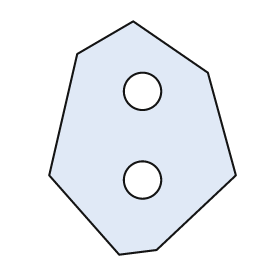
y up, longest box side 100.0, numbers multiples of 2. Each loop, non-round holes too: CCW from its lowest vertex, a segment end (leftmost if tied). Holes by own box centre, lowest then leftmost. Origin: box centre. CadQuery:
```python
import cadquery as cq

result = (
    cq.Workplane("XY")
    .moveTo(-10.0, -50.0)
    .lineTo(6.0, -48.0)
    .lineTo(40.0, -16.0)
    .lineTo(28.0, 28.0)
    .lineTo(-4.0, 50.0)
    .lineTo(-28.0, 36.0)
    .lineTo(-40.0, -16.0)
    .close()
    .moveTo(0.0, -18.0)
    .circle(8.0)
    .moveTo(0.0, 20.0)
    .circle(8.0)
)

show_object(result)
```